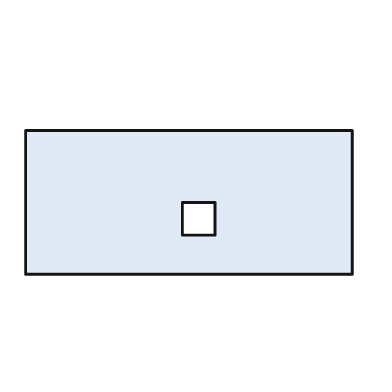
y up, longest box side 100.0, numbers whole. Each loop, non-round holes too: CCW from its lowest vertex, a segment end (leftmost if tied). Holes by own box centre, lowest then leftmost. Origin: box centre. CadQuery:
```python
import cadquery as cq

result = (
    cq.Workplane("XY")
    .moveTo(-50.0, -22.0)
    .lineTo(50.0, -22.0)
    .lineTo(50.0, 22.0)
    .lineTo(-50.0, 22.0)
    .close()
    .moveTo(-2.0, -10.0)
    .lineTo(8.0, -10.0)
    .lineTo(8.0, 0.0)
    .lineTo(-2.0, 0.0)
    .close()
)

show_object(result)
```